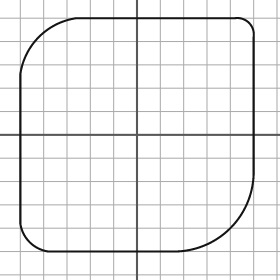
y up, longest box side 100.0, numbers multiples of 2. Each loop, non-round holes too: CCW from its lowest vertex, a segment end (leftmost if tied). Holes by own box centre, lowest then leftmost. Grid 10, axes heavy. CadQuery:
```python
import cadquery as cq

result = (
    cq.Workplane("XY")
    .moveTo(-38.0, -50.0)
    .lineTo(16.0, -50.0)
    .threePointArc((40.0, -40.0), (50.0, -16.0))
    .lineTo(50.0, 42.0)
    .threePointArc((48.0, 48.0), (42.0, 50.0))
    .lineTo(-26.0, 50.0)
    .threePointArc((-42.0, 42.0), (-50.0, 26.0))
    .lineTo(-50.0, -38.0)
    .threePointArc((-46.0, -46.0), (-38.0, -50.0))
    .close()
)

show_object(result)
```